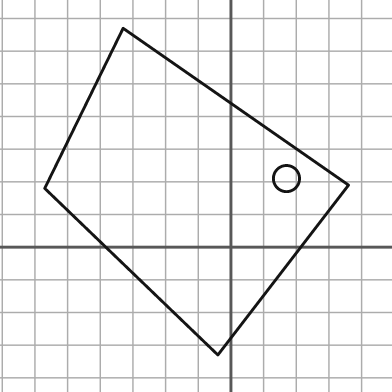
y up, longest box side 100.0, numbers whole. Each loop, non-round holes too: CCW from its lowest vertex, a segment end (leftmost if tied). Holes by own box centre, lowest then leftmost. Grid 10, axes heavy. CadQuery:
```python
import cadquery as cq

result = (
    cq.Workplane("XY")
    .moveTo(-4.0, -33.0)
    .lineTo(36.0, 19.0)
    .lineTo(-33.0, 67.0)
    .lineTo(-57.0, 18.0)
    .close()
    .moveTo(17.0, 21.0)
    .circle(4.0)
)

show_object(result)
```